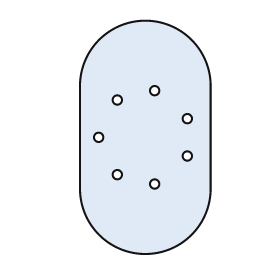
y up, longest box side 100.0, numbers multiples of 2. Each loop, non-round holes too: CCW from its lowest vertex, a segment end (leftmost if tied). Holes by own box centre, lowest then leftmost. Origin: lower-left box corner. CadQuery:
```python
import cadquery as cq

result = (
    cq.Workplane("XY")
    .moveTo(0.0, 28.0)
    .threePointArc((28.0, 0.0), (56.0, 28.0))
    .lineTo(56.0, 72.0)
    .threePointArc((28.0, 100.0), (0.0, 72.0))
    .close()
    .moveTo(32.0, 30.0)
    .circle(2.0)
    .moveTo(16.0, 34.0)
    .circle(2.0)
    .moveTo(46.0, 42.0)
    .circle(2.0)
    .moveTo(8.0, 50.0)
    .circle(2.0)
    .moveTo(46.0, 58.0)
    .circle(2.0)
    .moveTo(16.0, 66.0)
    .circle(2.0)
    .moveTo(32.0, 70.0)
    .circle(2.0)
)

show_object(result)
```